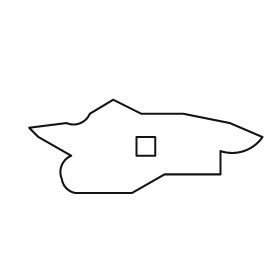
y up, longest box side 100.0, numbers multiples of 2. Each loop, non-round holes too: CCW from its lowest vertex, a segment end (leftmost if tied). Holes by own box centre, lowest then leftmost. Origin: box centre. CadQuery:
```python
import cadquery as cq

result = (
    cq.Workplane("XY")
    .moveTo(-30.0, -20.0)
    .lineTo(-6.0, -20.0)
    .lineTo(8.0, -12.0)
    .lineTo(32.0, -12.0)
    .lineTo(32.0, -2.0)
    .threePointArc((42.0, -2.0), (50.0, 4.0))
    .lineTo(36.0, 10.0)
    .lineTo(16.0, 14.0)
    .lineTo(-2.0, 14.0)
    .lineTo(-14.0, 20.0)
    .lineTo(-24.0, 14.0)
    .threePointArc((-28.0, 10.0), (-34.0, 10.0))
    .lineTo(-50.0, 8.0)
    .lineTo(-46.0, 4.0)
    .lineTo(-32.0, -4.0)
    .threePointArc((-36.0, -8.0), (-36.0, -14.0))
    .threePointArc((-34.0, -18.0), (-30.0, -20.0))
    .close()
    .moveTo(-4.0, -4.0)
    .lineTo(4.0, -4.0)
    .lineTo(4.0, 4.0)
    .lineTo(-4.0, 4.0)
    .close()
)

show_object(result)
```